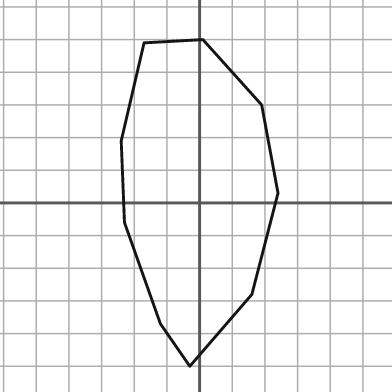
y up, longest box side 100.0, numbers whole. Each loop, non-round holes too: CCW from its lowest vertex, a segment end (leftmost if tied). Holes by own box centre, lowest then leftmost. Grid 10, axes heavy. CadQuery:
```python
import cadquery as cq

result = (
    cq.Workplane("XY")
    .moveTo(-3.0, -50.0)
    .lineTo(16.0, -28.0)
    .lineTo(24.0, 3.0)
    .lineTo(19.0, 30.0)
    .lineTo(1.0, 50.0)
    .lineTo(-17.0, 49.0)
    .lineTo(-24.0, 19.0)
    .lineTo(-23.0, -6.0)
    .lineTo(-12.0, -37.0)
    .close()
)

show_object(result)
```